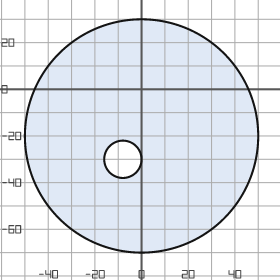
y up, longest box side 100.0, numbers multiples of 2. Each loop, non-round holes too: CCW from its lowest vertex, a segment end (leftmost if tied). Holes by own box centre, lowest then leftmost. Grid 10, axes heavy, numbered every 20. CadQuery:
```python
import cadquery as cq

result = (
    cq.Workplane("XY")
    .moveTo(0.0, -20.0)
    .circle(50.0)
    .moveTo(-8.0, -30.0)
    .circle(8.0)
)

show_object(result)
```